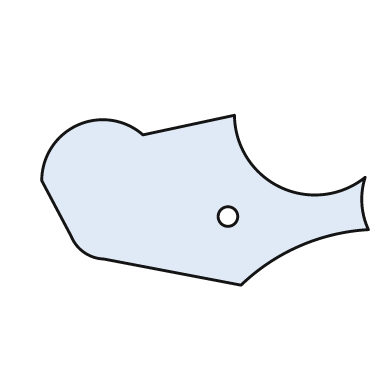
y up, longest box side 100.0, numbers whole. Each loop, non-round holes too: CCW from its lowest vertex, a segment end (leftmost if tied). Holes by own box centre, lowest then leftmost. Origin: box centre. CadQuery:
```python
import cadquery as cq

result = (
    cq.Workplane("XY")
    .moveTo(11.0, -26.0)
    .threePointArc((29.0, -14.0), (50.0, -9.0))
    .threePointArc((48.0, -1.0), (49.0, 7.0))
    .threePointArc((23.0, 4.0), (9.0, 26.0))
    .lineTo(-19.0, 20.0)
    .threePointArc((-39.0, 23.0), (-50.0, 6.0))
    .lineTo(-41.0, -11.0)
    .threePointArc((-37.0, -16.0), (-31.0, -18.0))
    .close()
    .moveTo(7.0, -5.0)
    .circle(3.0)
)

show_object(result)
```